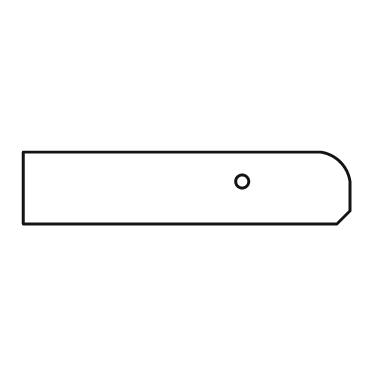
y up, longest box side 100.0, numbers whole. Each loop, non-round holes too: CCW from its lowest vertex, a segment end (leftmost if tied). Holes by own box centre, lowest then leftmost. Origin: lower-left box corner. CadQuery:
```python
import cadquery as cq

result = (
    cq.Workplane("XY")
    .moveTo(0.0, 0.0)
    .lineTo(96.0, 0.0)
    .lineTo(100.0, 4.0)
    .lineTo(100.0, 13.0)
    .threePointArc((97.0, 19.0), (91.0, 22.0))
    .lineTo(0.0, 22.0)
    .close()
    .moveTo(67.0, 13.0)
    .circle(2.0)
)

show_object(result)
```